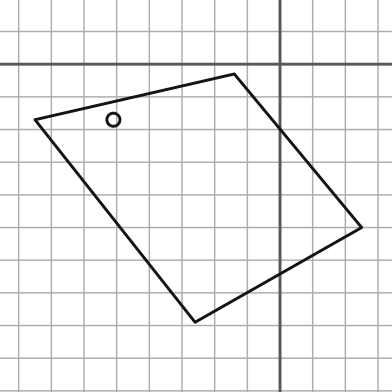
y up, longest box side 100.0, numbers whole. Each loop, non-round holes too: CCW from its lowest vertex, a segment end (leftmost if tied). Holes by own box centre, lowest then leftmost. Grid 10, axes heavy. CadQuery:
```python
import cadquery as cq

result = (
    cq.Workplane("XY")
    .moveTo(-26.0, -79.0)
    .lineTo(25.0, -50.0)
    .lineTo(-14.0, -3.0)
    .lineTo(-75.0, -17.0)
    .close()
    .moveTo(-51.0, -17.0)
    .circle(2.0)
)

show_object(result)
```